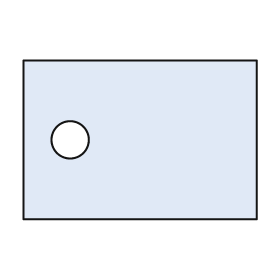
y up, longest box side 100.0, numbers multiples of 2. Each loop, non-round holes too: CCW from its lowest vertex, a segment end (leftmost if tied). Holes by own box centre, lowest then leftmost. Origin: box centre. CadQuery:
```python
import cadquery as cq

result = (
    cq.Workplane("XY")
    .moveTo(-50.0, -34.0)
    .lineTo(50.0, -34.0)
    .lineTo(50.0, 34.0)
    .lineTo(-50.0, 34.0)
    .close()
    .moveTo(-30.0, 0.0)
    .circle(8.0)
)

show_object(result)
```